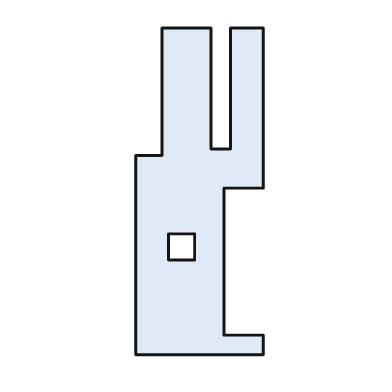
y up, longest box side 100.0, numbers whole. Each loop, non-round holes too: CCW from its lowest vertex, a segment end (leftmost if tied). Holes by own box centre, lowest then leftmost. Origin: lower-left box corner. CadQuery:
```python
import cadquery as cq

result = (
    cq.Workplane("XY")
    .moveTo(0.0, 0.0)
    .lineTo(39.0, 0.0)
    .lineTo(39.0, 6.0)
    .lineTo(27.0, 6.0)
    .lineTo(27.0, 51.0)
    .lineTo(39.0, 51.0)
    .lineTo(39.0, 100.0)
    .lineTo(29.0, 100.0)
    .lineTo(29.0, 63.0)
    .lineTo(23.0, 63.0)
    .lineTo(23.0, 100.0)
    .lineTo(8.0, 100.0)
    .lineTo(8.0, 61.0)
    .lineTo(0.0, 61.0)
    .close()
    .moveTo(10.0, 29.0)
    .lineTo(18.0, 29.0)
    .lineTo(18.0, 37.0)
    .lineTo(10.0, 37.0)
    .close()
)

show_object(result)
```